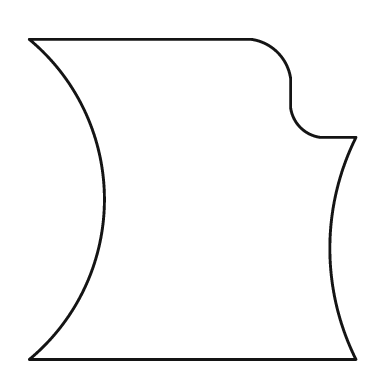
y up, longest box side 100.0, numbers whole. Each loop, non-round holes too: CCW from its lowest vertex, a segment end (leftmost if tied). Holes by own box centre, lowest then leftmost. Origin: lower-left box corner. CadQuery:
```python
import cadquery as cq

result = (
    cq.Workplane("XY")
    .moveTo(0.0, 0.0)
    .lineTo(100.0, 0.0)
    .threePointArc((92.0, 34.0), (100.0, 68.0))
    .lineTo(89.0, 68.0)
    .threePointArc((83.0, 71.0), (80.0, 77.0))
    .lineTo(80.0, 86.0)
    .threePointArc((76.0, 94.0), (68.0, 98.0))
    .lineTo(0.0, 98.0)
    .threePointArc((23.0, 49.0), (0.0, 0.0))
    .close()
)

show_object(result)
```